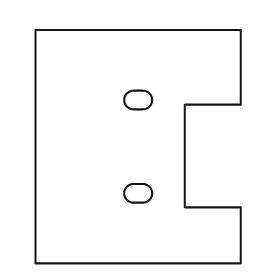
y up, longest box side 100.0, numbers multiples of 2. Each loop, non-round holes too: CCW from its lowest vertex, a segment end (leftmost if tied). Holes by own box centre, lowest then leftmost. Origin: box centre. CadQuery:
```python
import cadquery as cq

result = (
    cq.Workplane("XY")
    .moveTo(-44.0, -50.0)
    .lineTo(44.0, -50.0)
    .lineTo(44.0, -26.0)
    .lineTo(20.0, -26.0)
    .lineTo(20.0, 18.0)
    .lineTo(44.0, 18.0)
    .lineTo(44.0, 50.0)
    .lineTo(-44.0, 50.0)
    .close()
    .moveTo(-2.0, -24.0)
    .lineTo(2.0, -24.0)
    .threePointArc((6.0, -20.0), (2.0, -16.0))
    .lineTo(-2.0, -16.0)
    .threePointArc((-6.0, -20.0), (-2.0, -24.0))
    .close()
    .moveTo(-2.0, 16.0)
    .lineTo(2.0, 16.0)
    .threePointArc((6.0, 20.0), (2.0, 24.0))
    .lineTo(-2.0, 24.0)
    .threePointArc((-6.0, 20.0), (-2.0, 16.0))
    .close()
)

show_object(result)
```